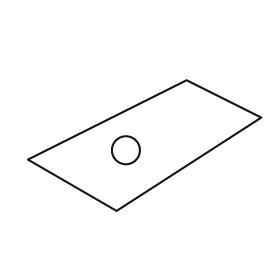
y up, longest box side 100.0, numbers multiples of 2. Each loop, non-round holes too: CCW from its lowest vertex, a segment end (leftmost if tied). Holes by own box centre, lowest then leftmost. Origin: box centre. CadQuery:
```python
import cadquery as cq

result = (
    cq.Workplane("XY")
    .moveTo(-12.0, -28.0)
    .lineTo(50.0, 12.0)
    .lineTo(18.0, 28.0)
    .lineTo(-50.0, -6.0)
    .close()
    .moveTo(-8.0, -2.0)
    .circle(6.0)
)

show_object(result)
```